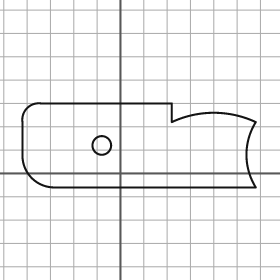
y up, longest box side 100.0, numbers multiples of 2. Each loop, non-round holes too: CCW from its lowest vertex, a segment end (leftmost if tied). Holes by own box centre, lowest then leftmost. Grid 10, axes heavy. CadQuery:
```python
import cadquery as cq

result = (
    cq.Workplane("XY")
    .moveTo(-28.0, -6.0)
    .lineTo(58.0, -6.0)
    .threePointArc((54.0, 8.0), (58.0, 22.0))
    .threePointArc((40.0, 26.0), (22.0, 22.0))
    .lineTo(22.0, 30.0)
    .lineTo(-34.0, 30.0)
    .threePointArc((-40.0, 28.0), (-42.0, 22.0))
    .lineTo(-42.0, 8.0)
    .threePointArc((-38.0, -2.0), (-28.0, -6.0))
    .close()
    .moveTo(-8.0, 12.0)
    .circle(4.0)
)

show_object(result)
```